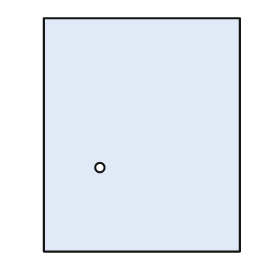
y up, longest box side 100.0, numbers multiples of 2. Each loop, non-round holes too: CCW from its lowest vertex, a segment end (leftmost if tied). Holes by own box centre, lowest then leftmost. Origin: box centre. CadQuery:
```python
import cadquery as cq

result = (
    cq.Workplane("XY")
    .moveTo(-42.0, -50.0)
    .lineTo(42.0, -50.0)
    .lineTo(42.0, 50.0)
    .lineTo(-42.0, 50.0)
    .close()
    .moveTo(-18.0, -14.0)
    .circle(2.0)
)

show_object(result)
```